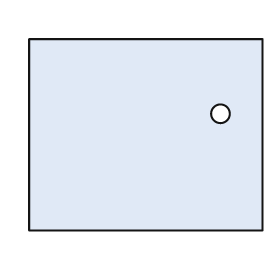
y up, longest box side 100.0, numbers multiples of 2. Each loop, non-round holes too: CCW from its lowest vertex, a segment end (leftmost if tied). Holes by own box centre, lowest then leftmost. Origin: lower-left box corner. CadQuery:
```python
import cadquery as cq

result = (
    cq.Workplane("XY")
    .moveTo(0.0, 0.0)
    .lineTo(100.0, 0.0)
    .lineTo(100.0, 82.0)
    .lineTo(0.0, 82.0)
    .close()
    .moveTo(82.0, 50.0)
    .circle(4.0)
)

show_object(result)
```